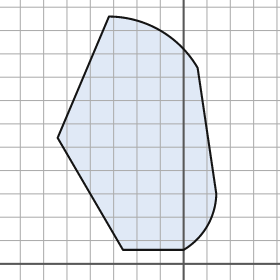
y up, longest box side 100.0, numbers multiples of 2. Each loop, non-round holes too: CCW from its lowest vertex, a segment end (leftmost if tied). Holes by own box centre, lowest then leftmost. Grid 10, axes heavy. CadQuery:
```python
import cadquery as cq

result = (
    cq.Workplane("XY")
    .moveTo(-26.0, 6.0)
    .lineTo(0.0, 6.0)
    .threePointArc((10.0, 16.0), (14.0, 30.0))
    .lineTo(6.0, 84.0)
    .threePointArc((-10.0, 100.0), (-32.0, 106.0))
    .lineTo(-54.0, 54.0)
    .close()
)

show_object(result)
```